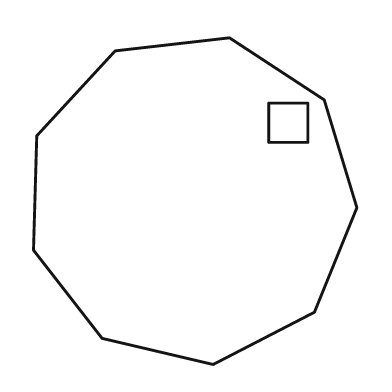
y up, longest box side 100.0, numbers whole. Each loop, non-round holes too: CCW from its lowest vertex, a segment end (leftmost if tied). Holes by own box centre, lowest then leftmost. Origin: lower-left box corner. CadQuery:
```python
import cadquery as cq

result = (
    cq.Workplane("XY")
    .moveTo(55.0, 0.0)
    .lineTo(86.0, 16.0)
    .lineTo(99.0, 48.0)
    .lineTo(89.0, 81.0)
    .lineTo(60.0, 100.0)
    .lineTo(25.0, 96.0)
    .lineTo(1.0, 70.0)
    .lineTo(0.0, 35.0)
    .lineTo(21.0, 8.0)
    .close()
    .moveTo(72.0, 68.0)
    .lineTo(84.0, 68.0)
    .lineTo(84.0, 80.0)
    .lineTo(72.0, 80.0)
    .close()
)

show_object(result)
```